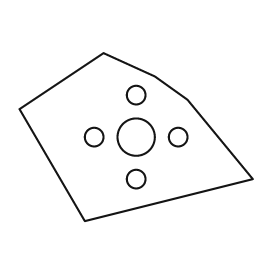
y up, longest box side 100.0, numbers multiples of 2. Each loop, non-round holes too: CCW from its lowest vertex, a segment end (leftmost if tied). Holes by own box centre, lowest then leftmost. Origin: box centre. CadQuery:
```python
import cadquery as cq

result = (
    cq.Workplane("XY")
    .moveTo(-22.0, -36.0)
    .lineTo(50.0, -18.0)
    .lineTo(22.0, 16.0)
    .lineTo(8.0, 26.0)
    .lineTo(-14.0, 36.0)
    .lineTo(-50.0, 12.0)
    .close()
    .moveTo(0.0, -18.0)
    .circle(4.0)
    .moveTo(-18.0, 0.0)
    .circle(4.0)
    .moveTo(0.0, 0.0)
    .circle(8.0)
    .moveTo(18.0, 0.0)
    .circle(4.0)
    .moveTo(0.0, 18.0)
    .circle(4.0)
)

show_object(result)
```